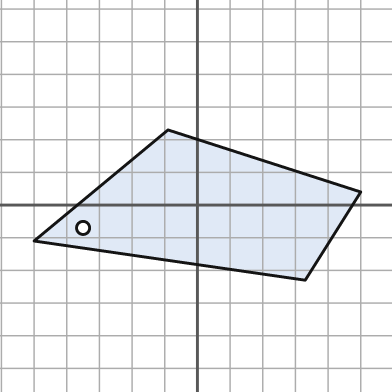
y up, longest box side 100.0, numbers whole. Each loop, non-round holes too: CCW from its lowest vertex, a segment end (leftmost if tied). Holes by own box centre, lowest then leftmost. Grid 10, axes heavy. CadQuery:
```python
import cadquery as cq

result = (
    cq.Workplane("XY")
    .moveTo(33.0, -23.0)
    .lineTo(50.0, 4.0)
    .lineTo(-9.0, 23.0)
    .lineTo(-50.0, -11.0)
    .close()
    .moveTo(-35.0, -7.0)
    .circle(2.0)
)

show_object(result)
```